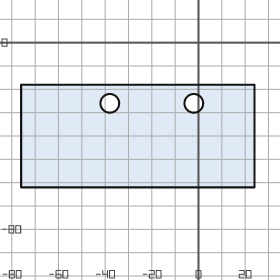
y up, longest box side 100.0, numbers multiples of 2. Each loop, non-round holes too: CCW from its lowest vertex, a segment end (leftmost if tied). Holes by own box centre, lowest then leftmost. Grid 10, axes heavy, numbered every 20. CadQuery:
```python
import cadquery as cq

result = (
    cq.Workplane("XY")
    .moveTo(-76.0, -62.0)
    .lineTo(24.0, -62.0)
    .lineTo(24.0, -18.0)
    .lineTo(-76.0, -18.0)
    .close()
    .moveTo(-38.0, -26.0)
    .circle(4.0)
    .moveTo(-2.0, -26.0)
    .circle(4.0)
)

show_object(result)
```